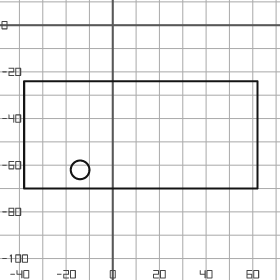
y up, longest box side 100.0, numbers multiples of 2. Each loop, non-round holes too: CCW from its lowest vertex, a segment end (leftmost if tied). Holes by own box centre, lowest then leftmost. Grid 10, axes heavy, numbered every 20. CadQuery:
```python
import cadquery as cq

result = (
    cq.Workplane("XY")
    .moveTo(-38.0, -70.0)
    .lineTo(62.0, -70.0)
    .lineTo(62.0, -24.0)
    .lineTo(-38.0, -24.0)
    .close()
    .moveTo(-14.0, -62.0)
    .circle(4.0)
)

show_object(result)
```